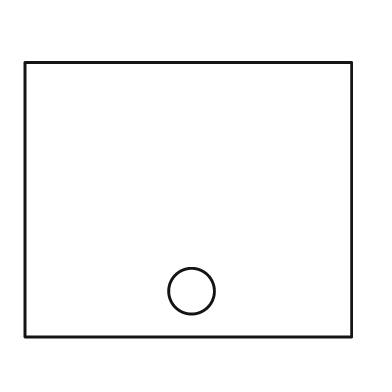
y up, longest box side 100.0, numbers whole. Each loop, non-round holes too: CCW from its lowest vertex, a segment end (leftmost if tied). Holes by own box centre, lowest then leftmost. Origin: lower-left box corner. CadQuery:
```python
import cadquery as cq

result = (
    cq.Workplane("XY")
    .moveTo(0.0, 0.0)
    .lineTo(100.0, 0.0)
    .lineTo(100.0, 84.0)
    .lineTo(0.0, 84.0)
    .close()
    .moveTo(51.0, 14.0)
    .circle(7.0)
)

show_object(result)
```